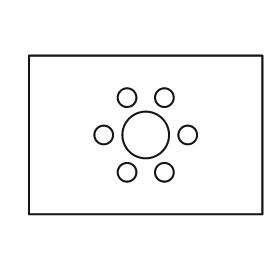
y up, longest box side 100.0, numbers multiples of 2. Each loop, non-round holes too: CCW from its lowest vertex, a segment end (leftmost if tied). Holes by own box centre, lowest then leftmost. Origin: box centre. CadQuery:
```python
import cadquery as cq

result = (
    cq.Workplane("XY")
    .moveTo(-50.0, -34.0)
    .lineTo(50.0, -34.0)
    .lineTo(50.0, 34.0)
    .lineTo(-50.0, 34.0)
    .close()
    .moveTo(-8.0, -16.0)
    .circle(4.0)
    .moveTo(8.0, -16.0)
    .circle(4.0)
    .moveTo(-18.0, 0.0)
    .circle(4.0)
    .moveTo(0.0, 0.0)
    .circle(10.0)
    .moveTo(18.0, 0.0)
    .circle(4.0)
    .moveTo(-8.0, 16.0)
    .circle(4.0)
    .moveTo(8.0, 16.0)
    .circle(4.0)
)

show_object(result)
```